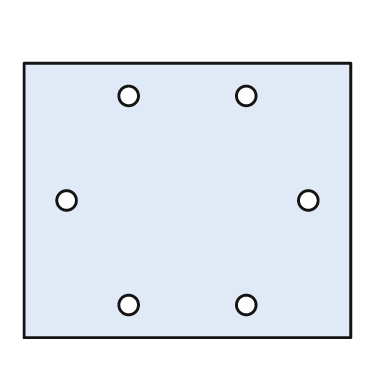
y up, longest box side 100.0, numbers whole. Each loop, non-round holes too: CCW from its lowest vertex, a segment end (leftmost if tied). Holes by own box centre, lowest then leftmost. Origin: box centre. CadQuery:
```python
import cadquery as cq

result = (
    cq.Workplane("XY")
    .moveTo(-50.0, -42.0)
    .lineTo(50.0, -42.0)
    .lineTo(50.0, 42.0)
    .lineTo(-50.0, 42.0)
    .close()
    .moveTo(-18.0, -32.0)
    .circle(3.0)
    .moveTo(18.0, -32.0)
    .circle(3.0)
    .moveTo(-37.0, 0.0)
    .circle(3.0)
    .moveTo(37.0, 0.0)
    .circle(3.0)
    .moveTo(-18.0, 32.0)
    .circle(3.0)
    .moveTo(18.0, 32.0)
    .circle(3.0)
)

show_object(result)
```